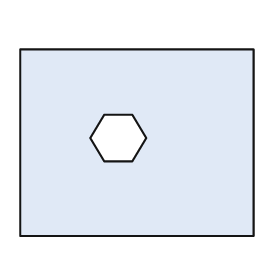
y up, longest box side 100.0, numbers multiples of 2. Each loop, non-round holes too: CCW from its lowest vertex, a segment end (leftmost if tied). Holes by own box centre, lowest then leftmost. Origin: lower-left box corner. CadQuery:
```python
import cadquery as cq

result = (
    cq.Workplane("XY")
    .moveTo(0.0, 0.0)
    .lineTo(100.0, 0.0)
    .lineTo(100.0, 80.0)
    .lineTo(0.0, 80.0)
    .close()
    .moveTo(36.0, 32.0)
    .lineTo(48.0, 32.0)
    .lineTo(54.0, 42.0)
    .lineTo(48.0, 52.0)
    .lineTo(36.0, 52.0)
    .lineTo(30.0, 42.0)
    .close()
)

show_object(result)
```